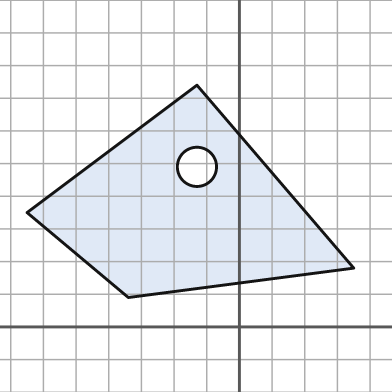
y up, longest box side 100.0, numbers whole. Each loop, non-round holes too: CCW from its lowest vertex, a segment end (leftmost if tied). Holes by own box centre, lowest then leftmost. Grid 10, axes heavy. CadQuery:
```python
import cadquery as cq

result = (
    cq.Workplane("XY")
    .moveTo(-34.0, 9.0)
    .lineTo(35.0, 18.0)
    .lineTo(-13.0, 74.0)
    .lineTo(-65.0, 35.0)
    .close()
    .moveTo(-13.0, 49.0)
    .circle(6.0)
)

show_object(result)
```